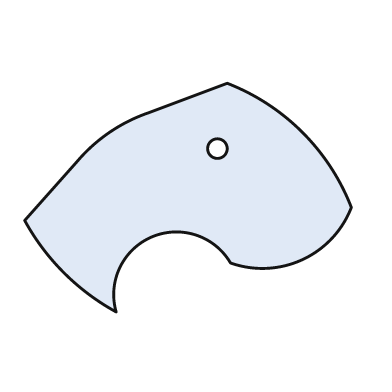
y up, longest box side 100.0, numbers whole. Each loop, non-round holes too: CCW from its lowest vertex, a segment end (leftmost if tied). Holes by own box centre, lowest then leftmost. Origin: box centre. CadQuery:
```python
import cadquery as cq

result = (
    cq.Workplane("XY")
    .moveTo(-22.0, -35.0)
    .threePointArc((-11.0, -12.0), (13.0, -20.0))
    .threePointArc((35.0, -19.0), (50.0, -3.0))
    .threePointArc((35.0, 20.0), (12.0, 35.0))
    .lineTo(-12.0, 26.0)
    .threePointArc((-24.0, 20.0), (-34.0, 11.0))
    .lineTo(-50.0, -7.0)
    .threePointArc((-38.0, -23.0), (-22.0, -35.0))
    .close()
    .moveTo(9.0, 15.0)
    .circle(3.0)
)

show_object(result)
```